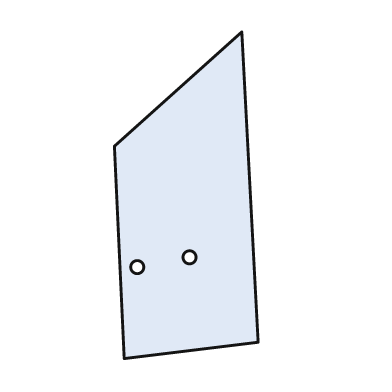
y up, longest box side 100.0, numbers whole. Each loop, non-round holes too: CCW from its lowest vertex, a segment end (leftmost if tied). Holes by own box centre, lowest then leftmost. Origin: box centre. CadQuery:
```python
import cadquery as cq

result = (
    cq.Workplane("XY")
    .moveTo(-19.0, -50.0)
    .lineTo(22.0, -45.0)
    .lineTo(17.0, 50.0)
    .lineTo(-22.0, 15.0)
    .close()
    .moveTo(-15.0, -22.0)
    .circle(2.0)
    .moveTo(1.0, -19.0)
    .circle(2.0)
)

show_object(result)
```